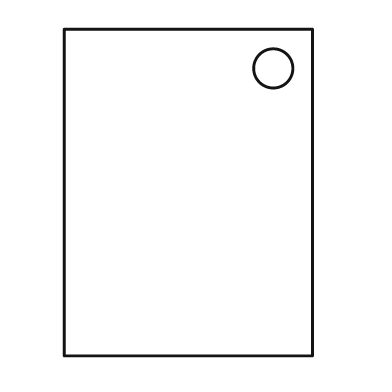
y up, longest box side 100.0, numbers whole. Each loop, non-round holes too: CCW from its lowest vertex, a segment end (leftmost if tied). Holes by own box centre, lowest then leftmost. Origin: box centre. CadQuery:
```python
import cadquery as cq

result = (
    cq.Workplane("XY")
    .moveTo(-38.0, -50.0)
    .lineTo(38.0, -50.0)
    .lineTo(38.0, 50.0)
    .lineTo(-38.0, 50.0)
    .close()
    .moveTo(26.0, 38.0)
    .circle(6.0)
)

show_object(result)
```